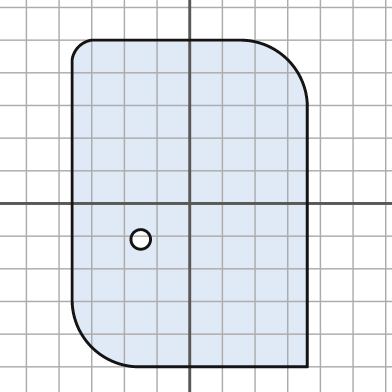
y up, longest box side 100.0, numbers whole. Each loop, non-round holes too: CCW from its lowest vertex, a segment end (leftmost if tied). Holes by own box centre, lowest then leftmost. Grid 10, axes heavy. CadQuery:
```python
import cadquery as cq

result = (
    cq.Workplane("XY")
    .moveTo(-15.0, -50.0)
    .lineTo(36.0, -50.0)
    .lineTo(36.0, 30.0)
    .threePointArc((30.0, 44.0), (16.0, 50.0))
    .lineTo(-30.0, 50.0)
    .threePointArc((-34.0, 48.0), (-36.0, 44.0))
    .lineTo(-36.0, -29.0)
    .threePointArc((-30.0, -44.0), (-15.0, -50.0))
    .close()
    .moveTo(-15.0, -11.0)
    .circle(3.0)
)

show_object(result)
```